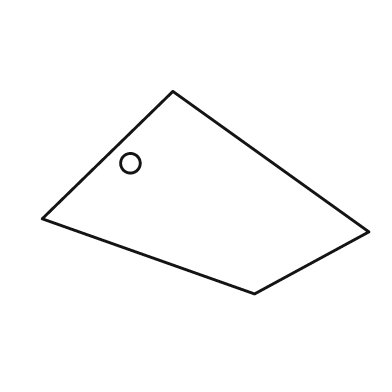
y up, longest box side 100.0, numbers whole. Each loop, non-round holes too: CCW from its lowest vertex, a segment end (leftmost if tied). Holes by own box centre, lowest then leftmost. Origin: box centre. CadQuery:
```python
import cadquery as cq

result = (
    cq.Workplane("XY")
    .moveTo(15.0, -31.0)
    .lineTo(50.0, -12.0)
    .lineTo(-10.0, 31.0)
    .lineTo(-50.0, -8.0)
    .close()
    .moveTo(-23.0, 9.0)
    .circle(3.0)
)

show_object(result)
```